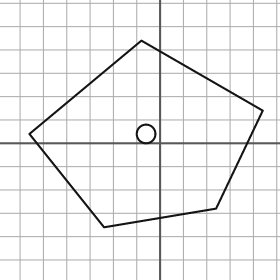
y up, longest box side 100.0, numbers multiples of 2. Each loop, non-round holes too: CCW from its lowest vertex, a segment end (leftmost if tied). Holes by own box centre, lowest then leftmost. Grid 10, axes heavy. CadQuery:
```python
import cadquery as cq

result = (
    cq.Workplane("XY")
    .moveTo(-24.0, -36.0)
    .lineTo(24.0, -28.0)
    .lineTo(44.0, 14.0)
    .lineTo(-8.0, 44.0)
    .lineTo(-56.0, 4.0)
    .close()
    .moveTo(-6.0, 4.0)
    .circle(4.0)
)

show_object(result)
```